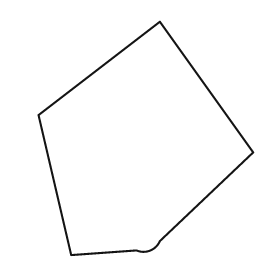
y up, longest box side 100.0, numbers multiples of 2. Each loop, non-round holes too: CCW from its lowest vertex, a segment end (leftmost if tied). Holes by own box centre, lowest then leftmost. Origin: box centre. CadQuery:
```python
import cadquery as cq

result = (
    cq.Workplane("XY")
    .moveTo(-32.0, -50.0)
    .lineTo(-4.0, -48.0)
    .threePointArc((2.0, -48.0), (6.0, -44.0))
    .lineTo(46.0, -6.0)
    .lineTo(6.0, 50.0)
    .lineTo(-46.0, 10.0)
    .close()
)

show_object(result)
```